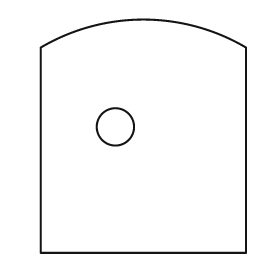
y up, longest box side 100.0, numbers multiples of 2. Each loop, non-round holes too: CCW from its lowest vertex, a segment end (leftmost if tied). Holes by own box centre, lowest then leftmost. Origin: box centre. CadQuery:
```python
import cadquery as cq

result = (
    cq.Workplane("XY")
    .moveTo(-44.0, -50.0)
    .lineTo(44.0, -50.0)
    .lineTo(44.0, 38.0)
    .threePointArc((0.0, 50.0), (-44.0, 38.0))
    .close()
    .moveTo(-12.0, 4.0)
    .circle(8.0)
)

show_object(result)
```